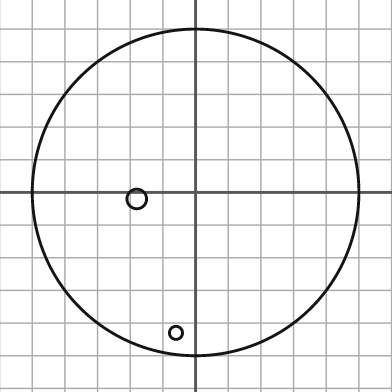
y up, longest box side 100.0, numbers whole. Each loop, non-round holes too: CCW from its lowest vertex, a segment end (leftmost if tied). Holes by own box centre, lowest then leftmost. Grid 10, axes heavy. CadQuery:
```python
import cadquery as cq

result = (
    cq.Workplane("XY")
    .moveTo(0.0, 0.0)
    .circle(50.0)
    .moveTo(-6.0, -43.0)
    .circle(2.0)
    .moveTo(-18.0, -2.0)
    .circle(3.0)
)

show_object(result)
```